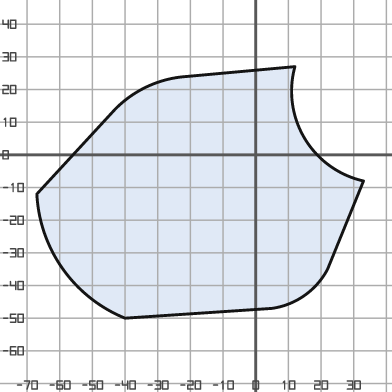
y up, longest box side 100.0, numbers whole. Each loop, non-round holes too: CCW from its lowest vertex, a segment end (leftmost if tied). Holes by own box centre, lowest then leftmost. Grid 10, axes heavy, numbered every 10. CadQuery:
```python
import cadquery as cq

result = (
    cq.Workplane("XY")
    .moveTo(-40.0, -50.0)
    .lineTo(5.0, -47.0)
    .threePointArc((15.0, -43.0), (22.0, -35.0))
    .lineTo(33.0, -8.0)
    .threePointArc((15.0, 5.0), (12.0, 27.0))
    .lineTo(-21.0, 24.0)
    .threePointArc((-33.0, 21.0), (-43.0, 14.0))
    .lineTo(-67.0, -12.0)
    .threePointArc((-59.0, -35.0), (-40.0, -50.0))
    .close()
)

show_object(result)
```